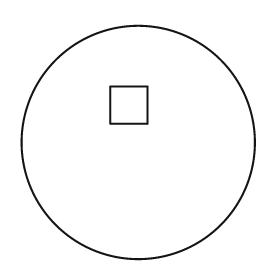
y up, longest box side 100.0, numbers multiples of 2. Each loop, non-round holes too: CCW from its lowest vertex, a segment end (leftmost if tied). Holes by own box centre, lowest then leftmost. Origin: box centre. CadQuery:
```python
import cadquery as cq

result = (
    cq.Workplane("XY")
    .moveTo(0.0, 0.0)
    .circle(50.0)
    .moveTo(-12.0, 8.0)
    .lineTo(4.0, 8.0)
    .lineTo(4.0, 24.0)
    .lineTo(-12.0, 24.0)
    .close()
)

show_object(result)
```